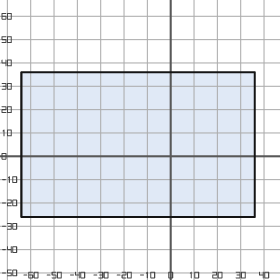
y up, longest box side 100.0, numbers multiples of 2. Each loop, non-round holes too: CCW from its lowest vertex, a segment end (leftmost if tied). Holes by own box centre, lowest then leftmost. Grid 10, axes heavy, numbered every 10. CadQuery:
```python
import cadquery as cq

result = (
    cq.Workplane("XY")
    .moveTo(-64.0, -26.0)
    .lineTo(36.0, -26.0)
    .lineTo(36.0, 36.0)
    .lineTo(-64.0, 36.0)
    .close()
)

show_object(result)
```